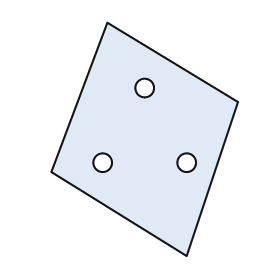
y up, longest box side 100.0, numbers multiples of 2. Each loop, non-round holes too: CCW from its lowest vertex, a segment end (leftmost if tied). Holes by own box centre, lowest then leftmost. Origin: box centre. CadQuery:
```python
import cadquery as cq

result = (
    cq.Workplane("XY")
    .moveTo(18.0, -50.0)
    .lineTo(40.0, 16.0)
    .lineTo(-16.0, 50.0)
    .lineTo(-40.0, -14.0)
    .close()
    .moveTo(-18.0, -10.0)
    .circle(4.0)
    .moveTo(18.0, -10.0)
    .circle(4.0)
    .moveTo(0.0, 22.0)
    .circle(4.0)
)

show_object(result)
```